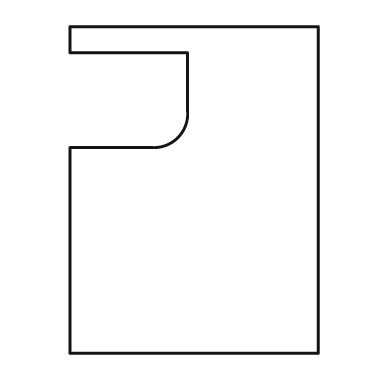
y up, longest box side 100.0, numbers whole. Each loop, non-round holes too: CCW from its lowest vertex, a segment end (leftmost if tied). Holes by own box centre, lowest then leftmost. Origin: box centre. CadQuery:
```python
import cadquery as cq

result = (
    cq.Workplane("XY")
    .moveTo(-38.0, -50.0)
    .lineTo(38.0, -50.0)
    .lineTo(38.0, 50.0)
    .lineTo(-38.0, 50.0)
    .lineTo(-38.0, 42.0)
    .lineTo(-2.0, 42.0)
    .lineTo(-2.0, 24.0)
    .threePointArc((-5.0, 16.0), (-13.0, 13.0))
    .lineTo(-38.0, 13.0)
    .close()
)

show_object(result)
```